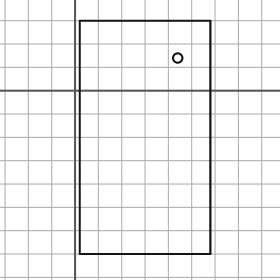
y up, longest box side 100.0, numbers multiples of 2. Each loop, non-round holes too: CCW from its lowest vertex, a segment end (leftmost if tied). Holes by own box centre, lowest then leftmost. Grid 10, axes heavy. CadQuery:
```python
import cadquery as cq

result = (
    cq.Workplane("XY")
    .moveTo(2.0, -70.0)
    .lineTo(58.0, -70.0)
    .lineTo(58.0, 30.0)
    .lineTo(2.0, 30.0)
    .close()
    .moveTo(44.0, 14.0)
    .circle(2.0)
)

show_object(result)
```